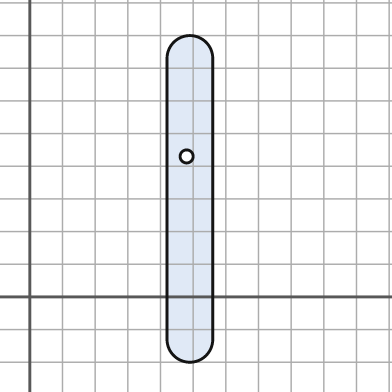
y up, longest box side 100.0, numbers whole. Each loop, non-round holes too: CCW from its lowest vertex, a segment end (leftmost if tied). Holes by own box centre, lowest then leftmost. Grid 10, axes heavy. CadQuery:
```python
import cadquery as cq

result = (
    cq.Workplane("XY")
    .moveTo(42.0, -13.0)
    .threePointArc((49.0, -20.0), (56.0, -13.0))
    .lineTo(56.0, 73.0)
    .threePointArc((49.0, 80.0), (42.0, 73.0))
    .close()
    .moveTo(48.0, 43.0)
    .circle(2.0)
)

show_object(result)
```